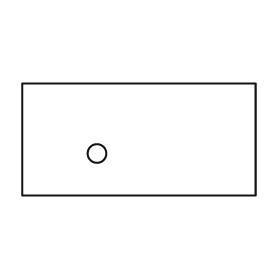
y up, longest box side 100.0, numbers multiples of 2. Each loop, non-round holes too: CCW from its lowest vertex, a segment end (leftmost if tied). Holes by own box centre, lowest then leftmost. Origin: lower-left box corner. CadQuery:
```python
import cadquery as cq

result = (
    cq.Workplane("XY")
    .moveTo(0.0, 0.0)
    .lineTo(100.0, 0.0)
    .lineTo(100.0, 48.0)
    .lineTo(0.0, 48.0)
    .close()
    .moveTo(32.0, 18.0)
    .circle(4.0)
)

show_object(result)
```